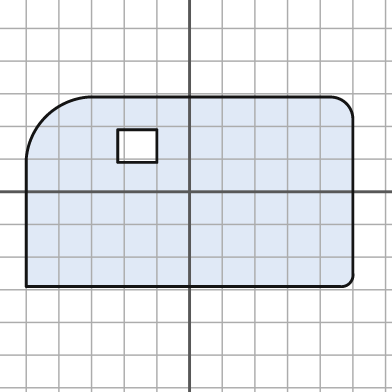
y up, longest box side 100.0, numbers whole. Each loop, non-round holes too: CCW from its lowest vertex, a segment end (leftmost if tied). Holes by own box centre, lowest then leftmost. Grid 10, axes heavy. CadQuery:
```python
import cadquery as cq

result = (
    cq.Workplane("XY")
    .moveTo(-50.0, -29.0)
    .lineTo(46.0, -29.0)
    .threePointArc((49.0, -28.0), (50.0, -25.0))
    .lineTo(50.0, 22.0)
    .threePointArc((48.0, 27.0), (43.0, 29.0))
    .lineTo(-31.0, 29.0)
    .threePointArc((-44.0, 23.0), (-50.0, 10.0))
    .close()
    .moveTo(-22.0, 9.0)
    .lineTo(-10.0, 9.0)
    .lineTo(-10.0, 19.0)
    .lineTo(-22.0, 19.0)
    .close()
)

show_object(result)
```